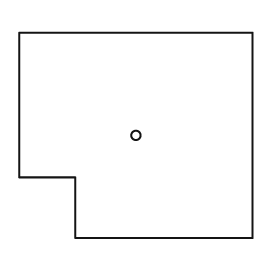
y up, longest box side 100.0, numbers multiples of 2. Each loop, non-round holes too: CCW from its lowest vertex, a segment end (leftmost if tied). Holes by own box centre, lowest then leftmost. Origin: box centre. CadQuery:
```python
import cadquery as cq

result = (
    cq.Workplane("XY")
    .moveTo(-26.0, -44.0)
    .lineTo(50.0, -44.0)
    .lineTo(50.0, 44.0)
    .lineTo(-50.0, 44.0)
    .lineTo(-50.0, -18.0)
    .lineTo(-26.0, -18.0)
    .close()
    .moveTo(0.0, 0.0)
    .circle(2.0)
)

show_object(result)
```